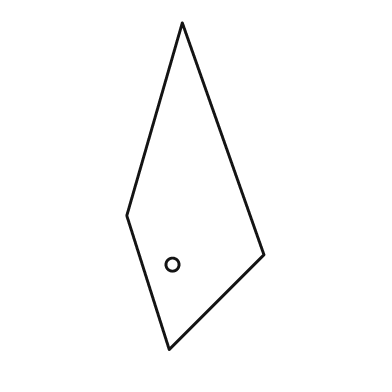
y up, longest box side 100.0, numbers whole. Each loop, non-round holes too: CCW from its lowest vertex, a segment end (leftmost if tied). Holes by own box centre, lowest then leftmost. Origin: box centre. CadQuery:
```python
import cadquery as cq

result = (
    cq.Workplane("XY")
    .moveTo(-8.0, -50.0)
    .lineTo(21.0, -21.0)
    .lineTo(-4.0, 50.0)
    .lineTo(-21.0, -9.0)
    .close()
    .moveTo(-7.0, -24.0)
    .circle(2.0)
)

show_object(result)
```